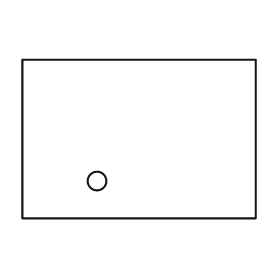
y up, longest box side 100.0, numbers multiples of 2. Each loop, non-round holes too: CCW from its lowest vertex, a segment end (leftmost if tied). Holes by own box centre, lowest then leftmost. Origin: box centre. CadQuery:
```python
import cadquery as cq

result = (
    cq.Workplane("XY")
    .moveTo(-50.0, -34.0)
    .lineTo(50.0, -34.0)
    .lineTo(50.0, 34.0)
    .lineTo(-50.0, 34.0)
    .close()
    .moveTo(-18.0, -18.0)
    .circle(4.0)
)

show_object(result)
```